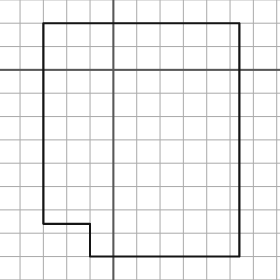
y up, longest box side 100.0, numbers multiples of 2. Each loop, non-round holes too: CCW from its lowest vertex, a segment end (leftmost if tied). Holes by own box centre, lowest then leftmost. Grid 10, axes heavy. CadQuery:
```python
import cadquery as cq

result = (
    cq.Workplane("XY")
    .moveTo(-10.0, -80.0)
    .lineTo(54.0, -80.0)
    .lineTo(54.0, 20.0)
    .lineTo(-30.0, 20.0)
    .lineTo(-30.0, -66.0)
    .lineTo(-10.0, -66.0)
    .close()
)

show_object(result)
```